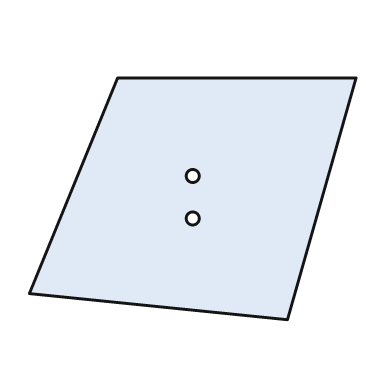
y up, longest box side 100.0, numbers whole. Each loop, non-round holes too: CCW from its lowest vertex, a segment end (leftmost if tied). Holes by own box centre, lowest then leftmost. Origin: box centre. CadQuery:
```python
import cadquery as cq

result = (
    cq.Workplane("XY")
    .moveTo(29.0, -37.0)
    .lineTo(50.0, 37.0)
    .lineTo(-23.0, 37.0)
    .lineTo(-50.0, -29.0)
    .close()
    .moveTo(0.0, -6.0)
    .circle(2.0)
    .moveTo(0.0, 7.0)
    .circle(2.0)
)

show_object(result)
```